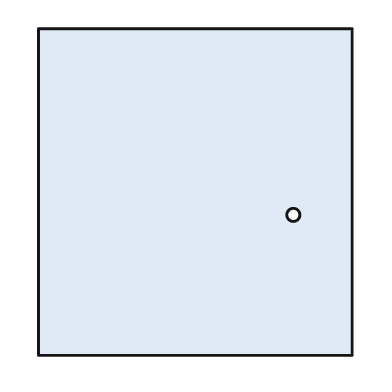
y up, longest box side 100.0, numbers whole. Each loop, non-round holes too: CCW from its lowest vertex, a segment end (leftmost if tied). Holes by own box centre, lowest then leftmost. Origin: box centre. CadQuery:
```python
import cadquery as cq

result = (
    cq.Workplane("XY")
    .moveTo(-48.0, -50.0)
    .lineTo(48.0, -50.0)
    .lineTo(48.0, 50.0)
    .lineTo(-48.0, 50.0)
    .close()
    .moveTo(30.0, -7.0)
    .circle(2.0)
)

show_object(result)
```